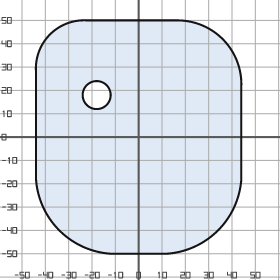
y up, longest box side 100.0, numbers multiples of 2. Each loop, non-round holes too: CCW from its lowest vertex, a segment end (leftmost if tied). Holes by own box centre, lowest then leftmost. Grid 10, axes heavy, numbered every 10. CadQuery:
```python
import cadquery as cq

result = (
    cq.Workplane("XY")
    .moveTo(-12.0, -50.0)
    .lineTo(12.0, -50.0)
    .threePointArc((34.0, -40.0), (44.0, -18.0))
    .lineTo(44.0, 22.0)
    .threePointArc((36.0, 42.0), (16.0, 50.0))
    .lineTo(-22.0, 50.0)
    .threePointArc((-38.0, 44.0), (-44.0, 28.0))
    .lineTo(-44.0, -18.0)
    .threePointArc((-34.0, -40.0), (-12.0, -50.0))
    .close()
    .moveTo(-18.0, 18.0)
    .circle(6.0)
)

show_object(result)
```